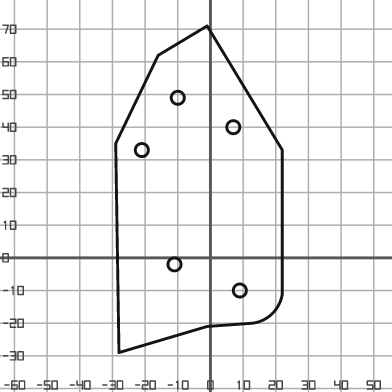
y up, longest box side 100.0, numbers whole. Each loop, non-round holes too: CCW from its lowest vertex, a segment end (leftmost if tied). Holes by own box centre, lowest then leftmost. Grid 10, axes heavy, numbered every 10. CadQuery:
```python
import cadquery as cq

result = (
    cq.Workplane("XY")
    .moveTo(-28.0, -29.0)
    .lineTo(-1.0, -21.0)
    .lineTo(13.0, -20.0)
    .threePointArc((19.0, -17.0), (22.0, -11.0))
    .lineTo(22.0, 33.0)
    .lineTo(-1.0, 71.0)
    .lineTo(-16.0, 62.0)
    .lineTo(-29.0, 35.0)
    .close()
    .moveTo(9.0, -10.0)
    .circle(2.0)
    .moveTo(-11.0, -2.0)
    .circle(2.0)
    .moveTo(-21.0, 33.0)
    .circle(2.0)
    .moveTo(7.0, 40.0)
    .circle(2.0)
    .moveTo(-10.0, 49.0)
    .circle(2.0)
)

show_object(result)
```